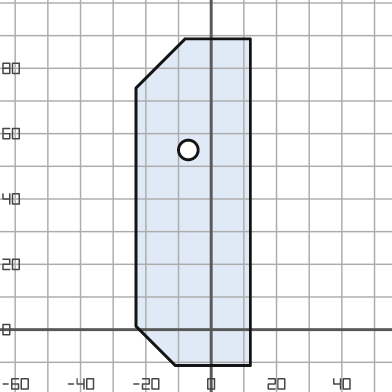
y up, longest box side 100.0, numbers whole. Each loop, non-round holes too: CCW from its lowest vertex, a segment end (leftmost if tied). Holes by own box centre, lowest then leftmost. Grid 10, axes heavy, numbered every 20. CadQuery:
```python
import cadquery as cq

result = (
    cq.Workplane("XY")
    .moveTo(-11.0, -11.0)
    .lineTo(12.0, -11.0)
    .lineTo(12.0, 89.0)
    .lineTo(-8.0, 89.0)
    .lineTo(-23.0, 74.0)
    .lineTo(-23.0, 1.0)
    .close()
    .moveTo(-7.0, 55.0)
    .circle(3.0)
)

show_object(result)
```